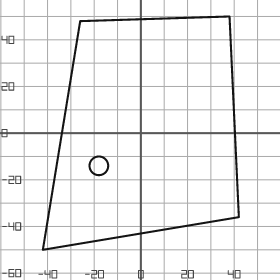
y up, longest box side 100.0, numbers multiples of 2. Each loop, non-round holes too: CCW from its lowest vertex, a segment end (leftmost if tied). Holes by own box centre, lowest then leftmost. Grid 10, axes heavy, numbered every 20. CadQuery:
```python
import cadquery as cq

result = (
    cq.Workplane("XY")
    .moveTo(-42.0, -50.0)
    .lineTo(42.0, -36.0)
    .lineTo(38.0, 50.0)
    .lineTo(-26.0, 48.0)
    .close()
    .moveTo(-18.0, -14.0)
    .circle(4.0)
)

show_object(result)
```